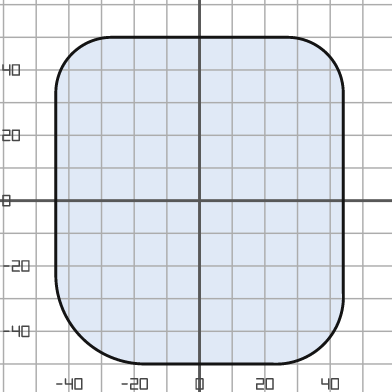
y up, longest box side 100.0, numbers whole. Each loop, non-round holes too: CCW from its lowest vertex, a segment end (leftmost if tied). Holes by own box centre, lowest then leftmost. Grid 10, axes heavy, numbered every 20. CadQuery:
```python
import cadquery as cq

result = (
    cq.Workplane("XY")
    .moveTo(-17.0, -50.0)
    .lineTo(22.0, -50.0)
    .threePointArc((38.0, -44.0), (44.0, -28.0))
    .lineTo(44.0, 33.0)
    .threePointArc((39.0, 45.0), (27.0, 50.0))
    .lineTo(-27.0, 50.0)
    .threePointArc((-39.0, 45.0), (-44.0, 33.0))
    .lineTo(-44.0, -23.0)
    .threePointArc((-36.0, -42.0), (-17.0, -50.0))
    .close()
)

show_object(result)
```